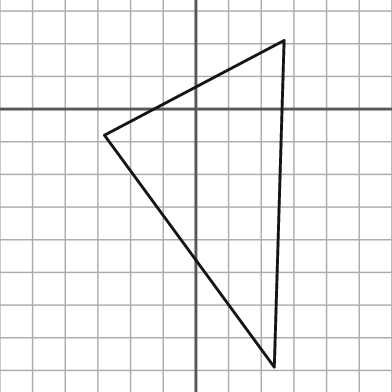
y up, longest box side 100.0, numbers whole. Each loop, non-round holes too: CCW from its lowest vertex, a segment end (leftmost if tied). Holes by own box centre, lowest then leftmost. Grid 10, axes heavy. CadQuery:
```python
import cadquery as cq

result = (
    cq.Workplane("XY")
    .moveTo(24.0, -79.0)
    .lineTo(27.0, 21.0)
    .lineTo(-28.0, -8.0)
    .close()
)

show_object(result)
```